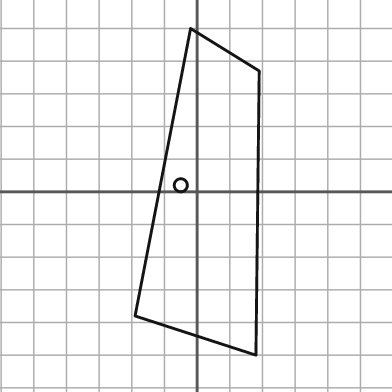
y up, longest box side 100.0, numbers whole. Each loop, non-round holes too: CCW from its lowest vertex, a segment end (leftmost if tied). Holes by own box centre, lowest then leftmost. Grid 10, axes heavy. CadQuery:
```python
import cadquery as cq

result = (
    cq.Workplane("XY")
    .moveTo(18.0, -50.0)
    .lineTo(19.0, 37.0)
    .lineTo(-2.0, 50.0)
    .lineTo(-19.0, -38.0)
    .close()
    .moveTo(-5.0, 2.0)
    .circle(2.0)
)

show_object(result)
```